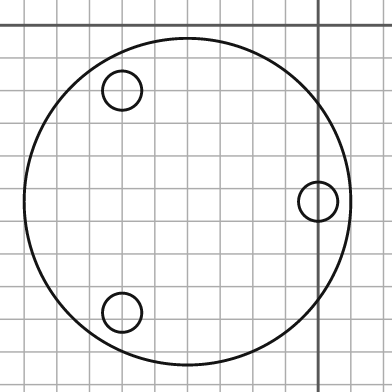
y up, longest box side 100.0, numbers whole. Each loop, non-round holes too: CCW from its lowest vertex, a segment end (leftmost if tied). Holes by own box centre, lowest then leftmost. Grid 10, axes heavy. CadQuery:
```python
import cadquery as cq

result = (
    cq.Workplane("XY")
    .moveTo(-40.0, -54.0)
    .circle(50.0)
    .moveTo(-60.0, -88.0)
    .circle(6.0)
    .moveTo(0.0, -54.0)
    .circle(6.0)
    .moveTo(-60.0, -20.0)
    .circle(6.0)
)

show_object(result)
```